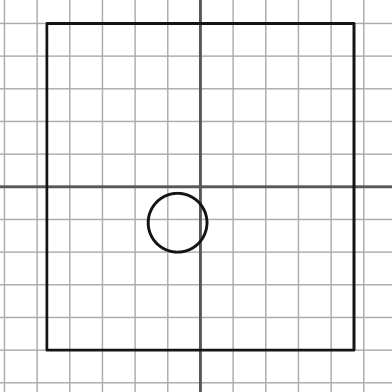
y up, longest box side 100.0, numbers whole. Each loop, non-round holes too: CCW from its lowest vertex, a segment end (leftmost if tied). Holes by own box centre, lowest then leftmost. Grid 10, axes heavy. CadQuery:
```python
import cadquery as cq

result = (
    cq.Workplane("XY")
    .moveTo(-47.0, -50.0)
    .lineTo(47.0, -50.0)
    .lineTo(47.0, 50.0)
    .lineTo(-47.0, 50.0)
    .close()
    .moveTo(-7.0, -11.0)
    .circle(9.0)
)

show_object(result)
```